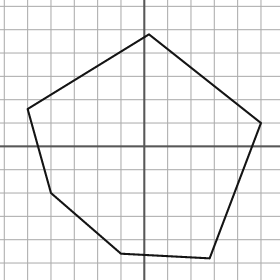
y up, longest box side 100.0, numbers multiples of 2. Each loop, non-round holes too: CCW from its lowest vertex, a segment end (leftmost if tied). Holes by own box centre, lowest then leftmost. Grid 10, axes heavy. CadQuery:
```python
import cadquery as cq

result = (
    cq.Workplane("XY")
    .moveTo(28.0, -48.0)
    .lineTo(50.0, 10.0)
    .lineTo(2.0, 48.0)
    .lineTo(-50.0, 16.0)
    .lineTo(-40.0, -20.0)
    .lineTo(-10.0, -46.0)
    .close()
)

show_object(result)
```